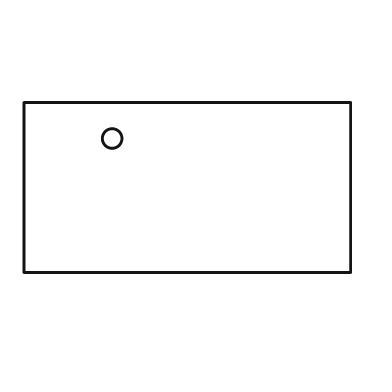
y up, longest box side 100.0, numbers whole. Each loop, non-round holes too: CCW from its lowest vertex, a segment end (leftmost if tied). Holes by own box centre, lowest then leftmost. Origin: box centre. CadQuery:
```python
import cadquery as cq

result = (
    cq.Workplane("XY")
    .moveTo(-50.0, -26.0)
    .lineTo(50.0, -26.0)
    .lineTo(50.0, 26.0)
    .lineTo(-50.0, 26.0)
    .close()
    .moveTo(-23.0, 15.0)
    .circle(3.0)
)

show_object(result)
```